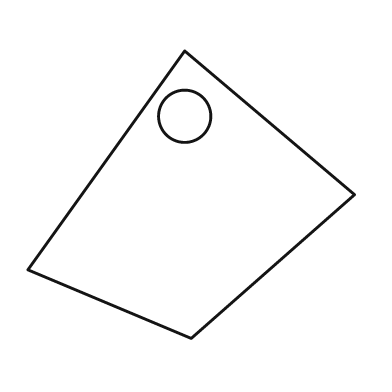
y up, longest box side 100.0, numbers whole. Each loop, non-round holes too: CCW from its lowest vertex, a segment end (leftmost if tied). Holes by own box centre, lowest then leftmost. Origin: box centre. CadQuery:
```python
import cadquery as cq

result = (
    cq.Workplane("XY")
    .moveTo(0.0, -44.0)
    .lineTo(50.0, 0.0)
    .lineTo(-2.0, 44.0)
    .lineTo(-50.0, -23.0)
    .close()
    .moveTo(-2.0, 24.0)
    .circle(8.0)
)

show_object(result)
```